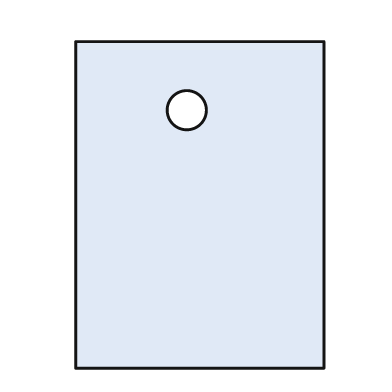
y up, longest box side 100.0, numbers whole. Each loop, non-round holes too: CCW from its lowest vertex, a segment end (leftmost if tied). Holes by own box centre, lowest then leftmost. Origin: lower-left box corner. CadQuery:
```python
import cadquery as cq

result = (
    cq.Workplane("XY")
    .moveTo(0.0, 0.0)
    .lineTo(76.0, 0.0)
    .lineTo(76.0, 100.0)
    .lineTo(0.0, 100.0)
    .close()
    .moveTo(34.0, 79.0)
    .circle(6.0)
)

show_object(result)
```